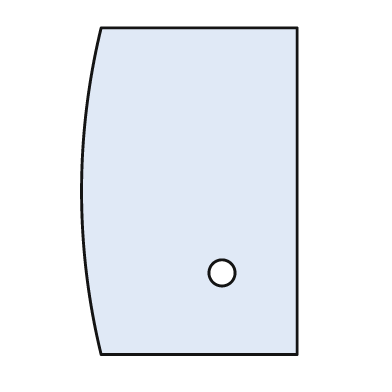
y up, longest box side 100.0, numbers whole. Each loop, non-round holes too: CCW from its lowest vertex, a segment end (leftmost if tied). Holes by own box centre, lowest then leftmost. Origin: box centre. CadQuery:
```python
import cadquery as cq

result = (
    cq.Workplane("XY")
    .moveTo(-27.0, -50.0)
    .lineTo(33.0, -50.0)
    .lineTo(33.0, 50.0)
    .lineTo(-27.0, 50.0)
    .threePointArc((-33.0, 0.0), (-27.0, -50.0))
    .close()
    .moveTo(10.0, -25.0)
    .circle(4.0)
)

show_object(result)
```